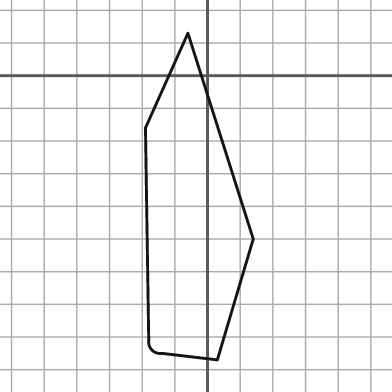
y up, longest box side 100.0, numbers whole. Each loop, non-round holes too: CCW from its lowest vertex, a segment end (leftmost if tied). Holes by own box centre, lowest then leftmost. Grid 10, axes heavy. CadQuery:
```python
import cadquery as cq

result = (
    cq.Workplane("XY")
    .moveTo(3.0, -87.0)
    .lineTo(14.0, -50.0)
    .lineTo(-6.0, 13.0)
    .lineTo(-19.0, -16.0)
    .lineTo(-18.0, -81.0)
    .threePointArc((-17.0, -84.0), (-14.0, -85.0))
    .close()
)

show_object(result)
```